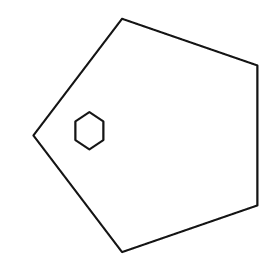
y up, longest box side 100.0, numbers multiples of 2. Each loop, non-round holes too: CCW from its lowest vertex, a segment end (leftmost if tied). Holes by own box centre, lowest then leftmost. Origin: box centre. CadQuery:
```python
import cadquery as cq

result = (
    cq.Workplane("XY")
    .moveTo(-10.0, -50.0)
    .lineTo(48.0, -30.0)
    .lineTo(48.0, 30.0)
    .lineTo(-10.0, 50.0)
    .lineTo(-48.0, 0.0)
    .close()
    .moveTo(-24.0, -6.0)
    .lineTo(-18.0, -2.0)
    .lineTo(-18.0, 6.0)
    .lineTo(-24.0, 10.0)
    .lineTo(-30.0, 6.0)
    .lineTo(-30.0, -2.0)
    .close()
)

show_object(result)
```